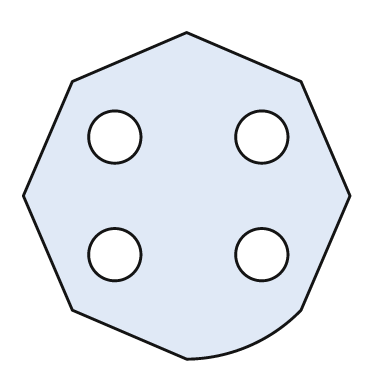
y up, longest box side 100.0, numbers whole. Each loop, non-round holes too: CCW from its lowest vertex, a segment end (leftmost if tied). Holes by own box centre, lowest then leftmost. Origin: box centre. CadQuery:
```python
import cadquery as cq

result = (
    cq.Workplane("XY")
    .moveTo(0.0, -50.0)
    .threePointArc((19.0, -46.0), (35.0, -35.0))
    .lineTo(50.0, 0.0)
    .lineTo(35.0, 35.0)
    .lineTo(0.0, 50.0)
    .lineTo(-35.0, 35.0)
    .lineTo(-50.0, 0.0)
    .lineTo(-35.0, -35.0)
    .close()
    .moveTo(-22.0, -18.0)
    .circle(8.0)
    .moveTo(23.0, -18.0)
    .circle(8.0)
    .moveTo(-22.0, 18.0)
    .circle(8.0)
    .moveTo(23.0, 18.0)
    .circle(8.0)
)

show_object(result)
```